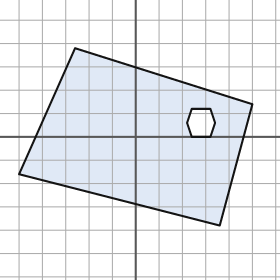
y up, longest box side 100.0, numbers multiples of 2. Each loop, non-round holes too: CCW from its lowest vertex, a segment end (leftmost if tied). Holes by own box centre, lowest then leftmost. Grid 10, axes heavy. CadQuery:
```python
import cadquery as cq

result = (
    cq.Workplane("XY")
    .moveTo(36.0, -38.0)
    .lineTo(50.0, 14.0)
    .lineTo(-26.0, 38.0)
    .lineTo(-50.0, -16.0)
    .close()
    .moveTo(24.0, 0.0)
    .lineTo(32.0, 0.0)
    .lineTo(34.0, 6.0)
    .lineTo(32.0, 12.0)
    .lineTo(24.0, 12.0)
    .lineTo(22.0, 6.0)
    .close()
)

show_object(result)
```